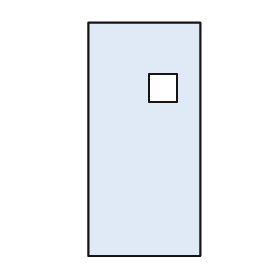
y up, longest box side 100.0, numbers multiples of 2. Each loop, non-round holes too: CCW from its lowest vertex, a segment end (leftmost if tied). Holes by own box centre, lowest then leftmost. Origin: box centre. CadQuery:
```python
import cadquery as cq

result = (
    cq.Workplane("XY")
    .moveTo(-24.0, -50.0)
    .lineTo(24.0, -50.0)
    .lineTo(24.0, 50.0)
    .lineTo(-24.0, 50.0)
    .close()
    .moveTo(2.0, 16.0)
    .lineTo(14.0, 16.0)
    .lineTo(14.0, 28.0)
    .lineTo(2.0, 28.0)
    .close()
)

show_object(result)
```